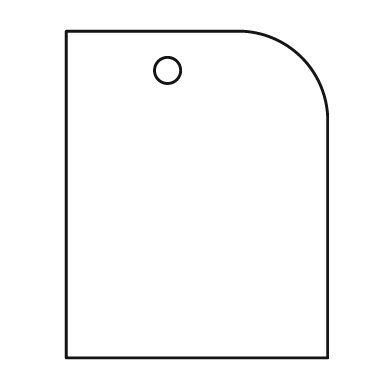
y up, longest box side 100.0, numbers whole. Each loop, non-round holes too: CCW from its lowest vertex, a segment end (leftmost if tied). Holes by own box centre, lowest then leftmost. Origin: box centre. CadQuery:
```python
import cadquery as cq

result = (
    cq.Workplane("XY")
    .moveTo(-40.0, -50.0)
    .lineTo(40.0, -50.0)
    .lineTo(40.0, 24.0)
    .threePointArc((32.0, 42.0), (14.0, 50.0))
    .lineTo(-40.0, 50.0)
    .close()
    .moveTo(-9.0, 38.0)
    .circle(4.0)
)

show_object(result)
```